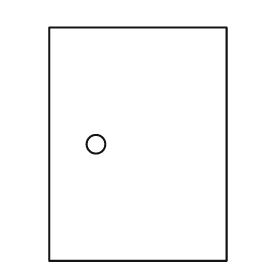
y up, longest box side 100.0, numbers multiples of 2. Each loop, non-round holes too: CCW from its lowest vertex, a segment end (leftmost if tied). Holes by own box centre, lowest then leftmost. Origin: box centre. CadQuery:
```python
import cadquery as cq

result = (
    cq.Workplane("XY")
    .moveTo(-38.0, -50.0)
    .lineTo(38.0, -50.0)
    .lineTo(38.0, 50.0)
    .lineTo(-38.0, 50.0)
    .close()
    .moveTo(-18.0, 0.0)
    .circle(4.0)
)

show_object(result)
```